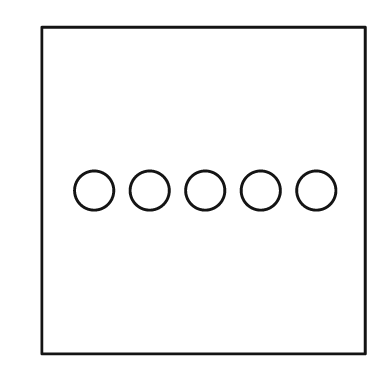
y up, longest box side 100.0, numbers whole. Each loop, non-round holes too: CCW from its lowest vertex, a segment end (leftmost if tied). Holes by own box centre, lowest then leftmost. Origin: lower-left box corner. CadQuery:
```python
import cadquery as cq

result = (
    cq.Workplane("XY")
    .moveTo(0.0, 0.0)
    .lineTo(99.0, 0.0)
    .lineTo(99.0, 100.0)
    .lineTo(0.0, 100.0)
    .close()
    .moveTo(16.0, 50.0)
    .circle(6.0)
    .moveTo(33.0, 50.0)
    .circle(6.0)
    .moveTo(50.0, 50.0)
    .circle(6.0)
    .moveTo(67.0, 50.0)
    .circle(6.0)
    .moveTo(84.0, 50.0)
    .circle(6.0)
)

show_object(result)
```